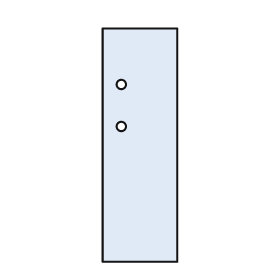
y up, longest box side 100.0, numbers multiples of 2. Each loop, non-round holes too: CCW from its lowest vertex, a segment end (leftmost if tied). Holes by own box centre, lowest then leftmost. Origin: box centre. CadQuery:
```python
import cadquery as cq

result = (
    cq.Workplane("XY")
    .moveTo(-16.0, -50.0)
    .lineTo(16.0, -50.0)
    .lineTo(16.0, 50.0)
    .lineTo(-16.0, 50.0)
    .close()
    .moveTo(-8.0, 8.0)
    .circle(2.0)
    .moveTo(-8.0, 26.0)
    .circle(2.0)
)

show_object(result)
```